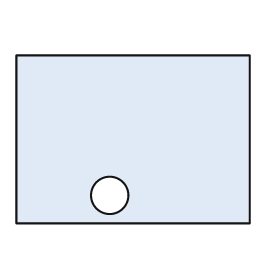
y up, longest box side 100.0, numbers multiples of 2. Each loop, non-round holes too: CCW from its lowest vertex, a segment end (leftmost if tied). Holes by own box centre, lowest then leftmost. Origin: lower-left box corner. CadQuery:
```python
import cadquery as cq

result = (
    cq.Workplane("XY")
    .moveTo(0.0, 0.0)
    .lineTo(100.0, 0.0)
    .lineTo(100.0, 72.0)
    .lineTo(0.0, 72.0)
    .close()
    .moveTo(40.0, 12.0)
    .circle(8.0)
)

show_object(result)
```